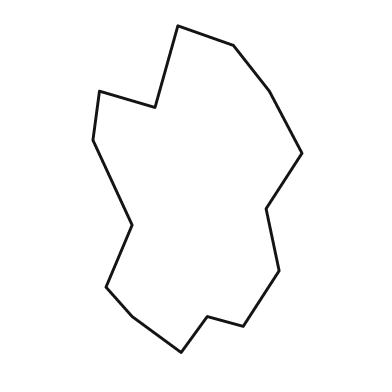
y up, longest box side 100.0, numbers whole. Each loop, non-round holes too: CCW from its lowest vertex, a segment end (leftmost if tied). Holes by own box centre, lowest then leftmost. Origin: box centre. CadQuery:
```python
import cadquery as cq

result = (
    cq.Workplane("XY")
    .moveTo(-5.0, -50.0)
    .lineTo(3.0, -39.0)
    .lineTo(14.0, -42.0)
    .lineTo(25.0, -25.0)
    .lineTo(21.0, -6.0)
    .lineTo(32.0, 11.0)
    .lineTo(22.0, 30.0)
    .lineTo(11.0, 44.0)
    .lineTo(-6.0, 50.0)
    .lineTo(-13.0, 25.0)
    .lineTo(-30.0, 30.0)
    .lineTo(-32.0, 15.0)
    .lineTo(-20.0, -11.0)
    .lineTo(-28.0, -30.0)
    .lineTo(-20.0, -39.0)
    .close()
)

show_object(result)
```